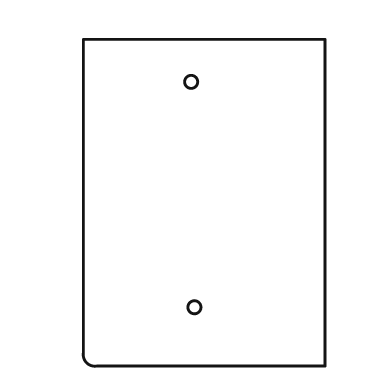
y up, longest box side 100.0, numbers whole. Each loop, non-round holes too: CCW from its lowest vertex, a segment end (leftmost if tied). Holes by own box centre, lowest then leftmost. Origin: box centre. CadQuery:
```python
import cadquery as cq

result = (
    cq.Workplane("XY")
    .moveTo(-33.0, -50.0)
    .lineTo(37.0, -50.0)
    .lineTo(37.0, 50.0)
    .lineTo(-37.0, 50.0)
    .lineTo(-37.0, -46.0)
    .threePointArc((-36.0, -49.0), (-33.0, -50.0))
    .close()
    .moveTo(-3.0, -32.0)
    .circle(2.0)
    .moveTo(-4.0, 37.0)
    .circle(2.0)
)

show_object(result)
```